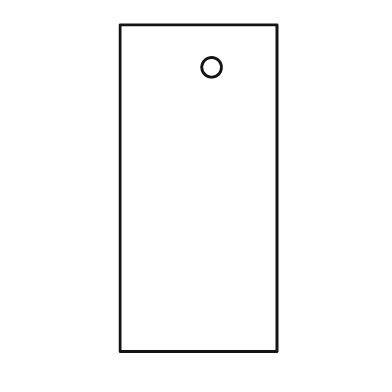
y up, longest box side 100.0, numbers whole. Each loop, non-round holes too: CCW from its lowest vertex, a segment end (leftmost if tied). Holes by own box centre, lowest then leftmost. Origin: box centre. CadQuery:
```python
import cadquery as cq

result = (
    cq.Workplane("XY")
    .moveTo(-24.0, -50.0)
    .lineTo(24.0, -50.0)
    .lineTo(24.0, 50.0)
    .lineTo(-24.0, 50.0)
    .close()
    .moveTo(4.0, 37.0)
    .circle(3.0)
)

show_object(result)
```